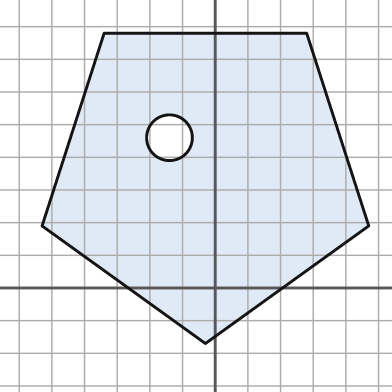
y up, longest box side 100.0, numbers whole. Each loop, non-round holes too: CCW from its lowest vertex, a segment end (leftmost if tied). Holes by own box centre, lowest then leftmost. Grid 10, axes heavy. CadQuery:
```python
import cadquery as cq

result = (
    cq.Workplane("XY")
    .moveTo(-3.0, -17.0)
    .lineTo(47.0, 19.0)
    .lineTo(28.0, 78.0)
    .lineTo(-34.0, 78.0)
    .lineTo(-53.0, 19.0)
    .close()
    .moveTo(-14.0, 46.0)
    .circle(7.0)
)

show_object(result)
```